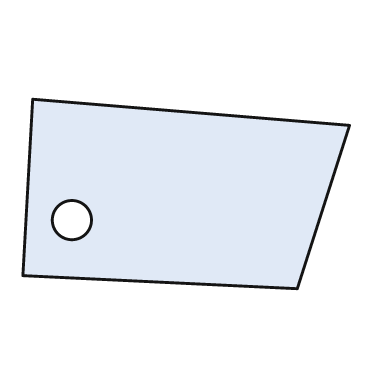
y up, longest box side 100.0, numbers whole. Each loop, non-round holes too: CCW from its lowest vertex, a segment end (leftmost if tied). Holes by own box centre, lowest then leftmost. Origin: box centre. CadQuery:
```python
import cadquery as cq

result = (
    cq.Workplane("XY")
    .moveTo(34.0, -29.0)
    .lineTo(50.0, 21.0)
    .lineTo(-47.0, 29.0)
    .lineTo(-50.0, -25.0)
    .close()
    .moveTo(-35.0, -8.0)
    .circle(6.0)
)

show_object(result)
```